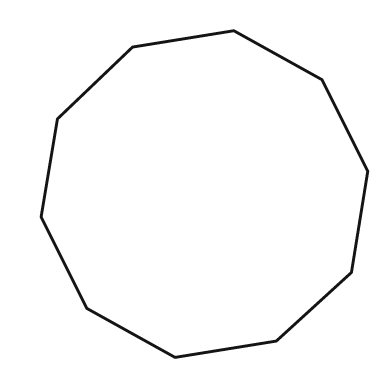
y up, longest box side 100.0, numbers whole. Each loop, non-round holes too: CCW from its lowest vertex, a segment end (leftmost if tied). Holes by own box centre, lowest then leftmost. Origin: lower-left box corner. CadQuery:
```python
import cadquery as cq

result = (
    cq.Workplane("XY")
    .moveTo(41.0, 0.0)
    .lineTo(72.0, 5.0)
    .lineTo(95.0, 26.0)
    .lineTo(100.0, 57.0)
    .lineTo(86.0, 85.0)
    .lineTo(59.0, 100.0)
    .lineTo(28.0, 95.0)
    .lineTo(5.0, 73.0)
    .lineTo(0.0, 43.0)
    .lineTo(14.0, 15.0)
    .close()
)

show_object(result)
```